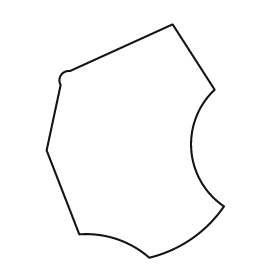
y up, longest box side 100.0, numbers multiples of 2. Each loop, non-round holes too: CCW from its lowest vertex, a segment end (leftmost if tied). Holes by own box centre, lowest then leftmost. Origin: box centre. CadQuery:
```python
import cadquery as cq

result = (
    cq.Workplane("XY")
    .moveTo(6.0, -50.0)
    .threePointArc((24.0, -42.0), (38.0, -28.0))
    .threePointArc((24.0, -4.0), (34.0, 22.0))
    .lineTo(16.0, 50.0)
    .lineTo(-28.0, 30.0)
    .threePointArc((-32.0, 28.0), (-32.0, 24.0))
    .lineTo(-38.0, -4.0)
    .lineTo(-24.0, -40.0)
    .threePointArc((-8.0, -42.0), (6.0, -50.0))
    .close()
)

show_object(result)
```